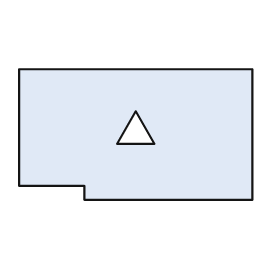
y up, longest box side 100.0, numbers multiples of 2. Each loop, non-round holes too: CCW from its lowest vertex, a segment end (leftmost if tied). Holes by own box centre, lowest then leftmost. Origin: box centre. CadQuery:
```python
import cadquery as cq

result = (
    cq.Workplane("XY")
    .moveTo(-22.0, -28.0)
    .lineTo(50.0, -28.0)
    .lineTo(50.0, 28.0)
    .lineTo(-50.0, 28.0)
    .lineTo(-50.0, -22.0)
    .lineTo(-22.0, -22.0)
    .close()
    .moveTo(-8.0, -4.0)
    .lineTo(8.0, -4.0)
    .lineTo(0.0, 10.0)
    .close()
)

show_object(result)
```